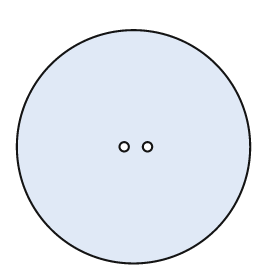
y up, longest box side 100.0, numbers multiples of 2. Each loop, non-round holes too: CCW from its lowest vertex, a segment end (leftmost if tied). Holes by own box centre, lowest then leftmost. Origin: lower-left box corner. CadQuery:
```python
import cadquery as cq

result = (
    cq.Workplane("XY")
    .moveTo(50.0, 50.0)
    .circle(50.0)
    .moveTo(46.0, 50.0)
    .circle(2.0)
    .moveTo(56.0, 50.0)
    .circle(2.0)
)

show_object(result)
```